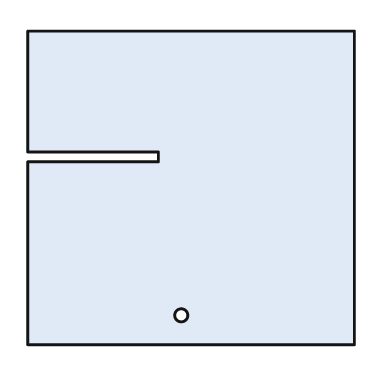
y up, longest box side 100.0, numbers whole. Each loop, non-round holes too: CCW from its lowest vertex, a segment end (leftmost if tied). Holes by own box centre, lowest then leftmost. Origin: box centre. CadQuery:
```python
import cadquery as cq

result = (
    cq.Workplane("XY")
    .moveTo(-50.0, -48.0)
    .lineTo(50.0, -48.0)
    .lineTo(50.0, 48.0)
    .lineTo(-50.0, 48.0)
    .lineTo(-50.0, 11.0)
    .lineTo(-10.0, 11.0)
    .lineTo(-10.0, 8.0)
    .lineTo(-50.0, 8.0)
    .close()
    .moveTo(-3.0, -39.0)
    .circle(2.0)
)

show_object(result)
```